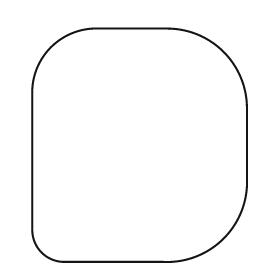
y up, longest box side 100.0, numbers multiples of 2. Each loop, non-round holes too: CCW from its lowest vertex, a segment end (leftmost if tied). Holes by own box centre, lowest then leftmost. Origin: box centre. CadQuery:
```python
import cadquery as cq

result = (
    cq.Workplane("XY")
    .moveTo(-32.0, -50.0)
    .lineTo(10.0, -50.0)
    .threePointArc((36.0, -40.0), (46.0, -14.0))
    .lineTo(46.0, 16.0)
    .threePointArc((36.0, 40.0), (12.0, 50.0))
    .lineTo(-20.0, 50.0)
    .threePointArc((-38.0, 42.0), (-46.0, 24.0))
    .lineTo(-46.0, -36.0)
    .threePointArc((-42.0, -46.0), (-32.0, -50.0))
    .close()
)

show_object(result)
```